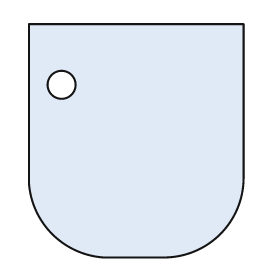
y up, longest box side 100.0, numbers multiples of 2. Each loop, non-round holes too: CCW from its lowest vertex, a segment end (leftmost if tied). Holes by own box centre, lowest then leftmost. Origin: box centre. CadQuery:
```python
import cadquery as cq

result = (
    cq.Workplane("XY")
    .moveTo(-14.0, -50.0)
    .lineTo(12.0, -50.0)
    .threePointArc((36.0, -40.0), (46.0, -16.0))
    .lineTo(46.0, 50.0)
    .lineTo(-46.0, 50.0)
    .lineTo(-46.0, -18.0)
    .threePointArc((-36.0, -40.0), (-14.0, -50.0))
    .close()
    .moveTo(-32.0, 24.0)
    .circle(6.0)
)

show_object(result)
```